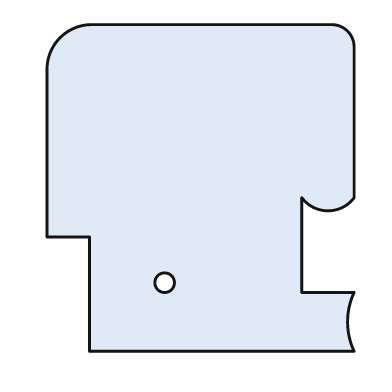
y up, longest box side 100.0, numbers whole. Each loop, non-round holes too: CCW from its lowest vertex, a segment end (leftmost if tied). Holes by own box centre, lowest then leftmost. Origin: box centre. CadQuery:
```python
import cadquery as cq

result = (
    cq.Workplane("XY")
    .moveTo(-34.0, -50.0)
    .lineTo(47.0, -50.0)
    .threePointArc((45.0, -41.0), (47.0, -32.0))
    .lineTo(31.0, -32.0)
    .lineTo(31.0, -3.0)
    .threePointArc((39.0, -7.0), (47.0, -3.0))
    .lineTo(47.0, 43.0)
    .threePointArc((45.0, 48.0), (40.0, 50.0))
    .lineTo(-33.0, 50.0)
    .threePointArc((-43.0, 46.0), (-47.0, 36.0))
    .lineTo(-47.0, -15.0)
    .lineTo(-34.0, -15.0)
    .close()
    .moveTo(-11.0, -29.0)
    .circle(3.0)
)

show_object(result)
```